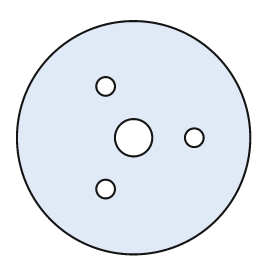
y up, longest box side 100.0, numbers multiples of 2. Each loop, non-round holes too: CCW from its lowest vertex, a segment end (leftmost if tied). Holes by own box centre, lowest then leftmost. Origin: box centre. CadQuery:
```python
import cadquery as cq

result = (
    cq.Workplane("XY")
    .moveTo(0.0, 0.0)
    .circle(50.0)
    .moveTo(-12.0, -22.0)
    .circle(4.0)
    .moveTo(0.0, 0.0)
    .circle(8.0)
    .moveTo(26.0, 0.0)
    .circle(4.0)
    .moveTo(-12.0, 22.0)
    .circle(4.0)
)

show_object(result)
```